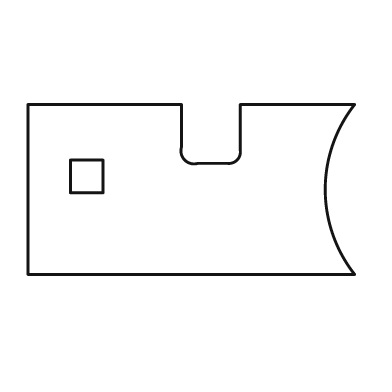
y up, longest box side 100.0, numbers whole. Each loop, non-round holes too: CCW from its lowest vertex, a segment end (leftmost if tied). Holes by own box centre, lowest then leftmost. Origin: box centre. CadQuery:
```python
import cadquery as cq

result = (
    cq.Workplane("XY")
    .moveTo(-50.0, -26.0)
    .lineTo(50.0, -26.0)
    .threePointArc((41.0, 0.0), (50.0, 26.0))
    .lineTo(15.0, 26.0)
    .lineTo(15.0, 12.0)
    .threePointArc((14.0, 9.0), (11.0, 8.0))
    .lineTo(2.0, 8.0)
    .threePointArc((-2.0, 9.0), (-3.0, 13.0))
    .lineTo(-3.0, 26.0)
    .lineTo(-50.0, 26.0)
    .close()
    .moveTo(-37.0, -1.0)
    .lineTo(-27.0, -1.0)
    .lineTo(-27.0, 9.0)
    .lineTo(-37.0, 9.0)
    .close()
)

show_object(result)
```